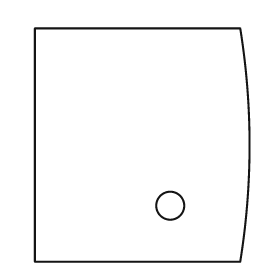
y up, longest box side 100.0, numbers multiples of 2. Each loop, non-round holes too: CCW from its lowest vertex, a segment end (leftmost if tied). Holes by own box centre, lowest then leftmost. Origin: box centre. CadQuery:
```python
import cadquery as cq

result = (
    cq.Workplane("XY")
    .moveTo(-46.0, -50.0)
    .lineTo(42.0, -50.0)
    .threePointArc((46.0, 0.0), (42.0, 50.0))
    .lineTo(-46.0, 50.0)
    .close()
    .moveTo(12.0, -26.0)
    .circle(6.0)
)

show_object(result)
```